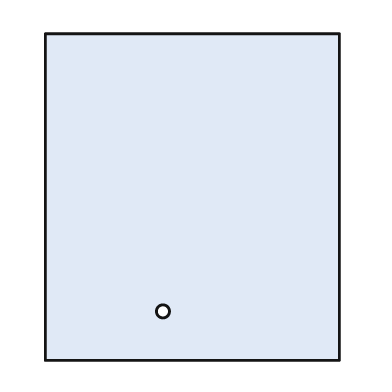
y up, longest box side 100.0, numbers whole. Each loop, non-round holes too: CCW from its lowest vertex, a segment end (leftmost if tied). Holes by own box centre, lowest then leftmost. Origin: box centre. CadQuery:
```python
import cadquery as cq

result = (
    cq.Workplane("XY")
    .moveTo(-45.0, -50.0)
    .lineTo(45.0, -50.0)
    .lineTo(45.0, 50.0)
    .lineTo(-45.0, 50.0)
    .close()
    .moveTo(-9.0, -35.0)
    .circle(2.0)
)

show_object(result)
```